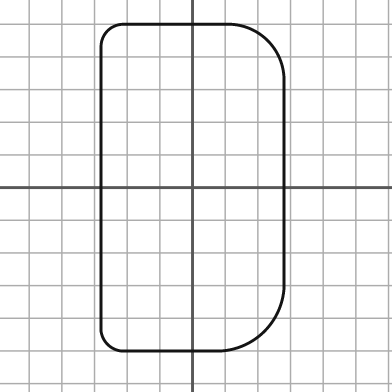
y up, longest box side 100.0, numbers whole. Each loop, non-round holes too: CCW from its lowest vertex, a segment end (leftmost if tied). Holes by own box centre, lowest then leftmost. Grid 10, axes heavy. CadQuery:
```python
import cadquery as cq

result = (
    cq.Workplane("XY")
    .moveTo(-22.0, -50.0)
    .lineTo(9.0, -50.0)
    .threePointArc((22.0, -44.0), (28.0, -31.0))
    .lineTo(28.0, 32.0)
    .threePointArc((23.0, 45.0), (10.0, 50.0))
    .lineTo(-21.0, 50.0)
    .threePointArc((-26.0, 48.0), (-28.0, 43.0))
    .lineTo(-28.0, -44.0)
    .threePointArc((-26.0, -48.0), (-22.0, -50.0))
    .close()
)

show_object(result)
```